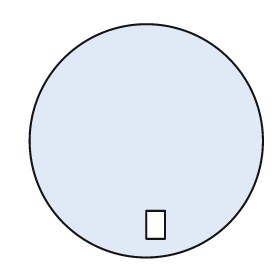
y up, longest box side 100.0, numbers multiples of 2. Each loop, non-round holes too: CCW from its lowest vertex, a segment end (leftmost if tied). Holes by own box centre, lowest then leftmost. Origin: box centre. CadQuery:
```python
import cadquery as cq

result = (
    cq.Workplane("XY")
    .moveTo(0.0, 0.0)
    .circle(50.0)
    .moveTo(0.0, -42.0)
    .lineTo(8.0, -42.0)
    .lineTo(8.0, -30.0)
    .lineTo(0.0, -30.0)
    .close()
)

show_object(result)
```